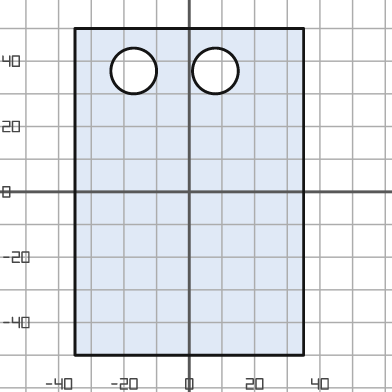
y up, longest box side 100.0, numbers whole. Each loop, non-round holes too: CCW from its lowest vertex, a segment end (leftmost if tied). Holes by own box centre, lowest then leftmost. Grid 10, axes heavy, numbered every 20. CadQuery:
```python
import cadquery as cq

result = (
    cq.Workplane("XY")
    .moveTo(-35.0, -50.0)
    .lineTo(35.0, -50.0)
    .lineTo(35.0, 50.0)
    .lineTo(-35.0, 50.0)
    .close()
    .moveTo(-17.0, 37.0)
    .circle(7.0)
    .moveTo(8.0, 37.0)
    .circle(7.0)
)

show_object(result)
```